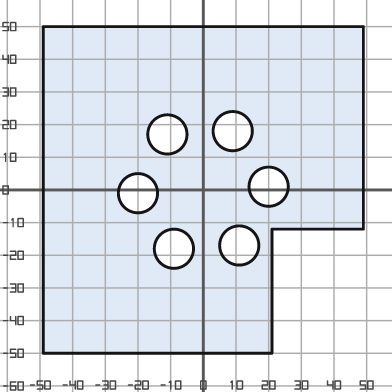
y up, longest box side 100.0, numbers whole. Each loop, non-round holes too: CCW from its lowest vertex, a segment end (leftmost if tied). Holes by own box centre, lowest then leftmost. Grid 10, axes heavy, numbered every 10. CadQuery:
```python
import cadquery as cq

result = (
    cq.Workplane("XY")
    .moveTo(-49.0, -50.0)
    .lineTo(21.0, -50.0)
    .lineTo(21.0, -12.0)
    .lineTo(49.0, -12.0)
    .lineTo(49.0, 50.0)
    .lineTo(-49.0, 50.0)
    .close()
    .moveTo(-9.0, -18.0)
    .circle(6.0)
    .moveTo(11.0, -17.0)
    .circle(6.0)
    .moveTo(-20.0, -1.0)
    .circle(6.0)
    .moveTo(20.0, 1.0)
    .circle(6.0)
    .moveTo(-11.0, 17.0)
    .circle(6.0)
    .moveTo(9.0, 18.0)
    .circle(6.0)
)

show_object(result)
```